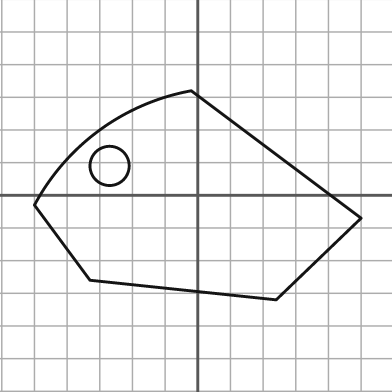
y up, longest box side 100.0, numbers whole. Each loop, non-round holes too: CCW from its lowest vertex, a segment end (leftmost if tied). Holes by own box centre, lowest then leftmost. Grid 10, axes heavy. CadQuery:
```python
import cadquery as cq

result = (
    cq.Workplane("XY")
    .moveTo(24.0, -32.0)
    .lineTo(50.0, -7.0)
    .lineTo(-2.0, 32.0)
    .threePointArc((-30.0, 20.0), (-50.0, -3.0))
    .lineTo(-33.0, -26.0)
    .close()
    .moveTo(-27.0, 9.0)
    .circle(6.0)
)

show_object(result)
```